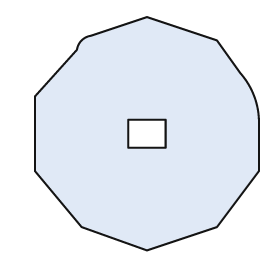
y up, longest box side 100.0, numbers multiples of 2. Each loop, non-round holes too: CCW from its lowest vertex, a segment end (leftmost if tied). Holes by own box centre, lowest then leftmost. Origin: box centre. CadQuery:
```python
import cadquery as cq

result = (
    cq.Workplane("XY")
    .moveTo(0.0, -50.0)
    .lineTo(30.0, -40.0)
    .lineTo(48.0, -16.0)
    .lineTo(48.0, 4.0)
    .threePointArc((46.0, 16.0), (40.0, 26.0))
    .lineTo(30.0, 40.0)
    .lineTo(0.0, 50.0)
    .lineTo(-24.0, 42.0)
    .threePointArc((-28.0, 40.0), (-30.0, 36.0))
    .lineTo(-48.0, 16.0)
    .lineTo(-48.0, -16.0)
    .lineTo(-28.0, -40.0)
    .close()
    .moveTo(-8.0, -6.0)
    .lineTo(8.0, -6.0)
    .lineTo(8.0, 6.0)
    .lineTo(-8.0, 6.0)
    .close()
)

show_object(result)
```